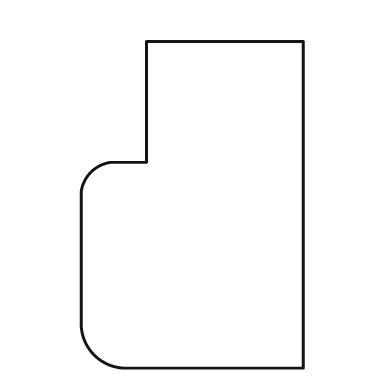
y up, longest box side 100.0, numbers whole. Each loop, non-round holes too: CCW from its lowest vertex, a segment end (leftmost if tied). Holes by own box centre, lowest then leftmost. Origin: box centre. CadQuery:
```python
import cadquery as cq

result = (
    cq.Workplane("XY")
    .moveTo(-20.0, -50.0)
    .lineTo(34.0, -50.0)
    .lineTo(34.0, 50.0)
    .lineTo(-14.0, 50.0)
    .lineTo(-14.0, 13.0)
    .lineTo(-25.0, 13.0)
    .threePointArc((-31.0, 10.0), (-34.0, 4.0))
    .lineTo(-34.0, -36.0)
    .threePointArc((-30.0, -46.0), (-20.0, -50.0))
    .close()
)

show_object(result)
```